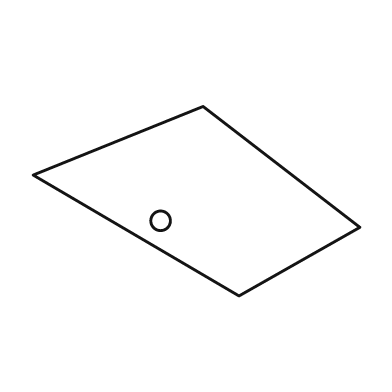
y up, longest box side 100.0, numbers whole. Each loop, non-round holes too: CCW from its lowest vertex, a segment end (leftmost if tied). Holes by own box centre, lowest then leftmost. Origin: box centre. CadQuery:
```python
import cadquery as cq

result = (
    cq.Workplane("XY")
    .moveTo(13.0, -29.0)
    .lineTo(50.0, -8.0)
    .lineTo(2.0, 29.0)
    .lineTo(-50.0, 8.0)
    .close()
    .moveTo(-11.0, -6.0)
    .circle(3.0)
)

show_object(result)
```